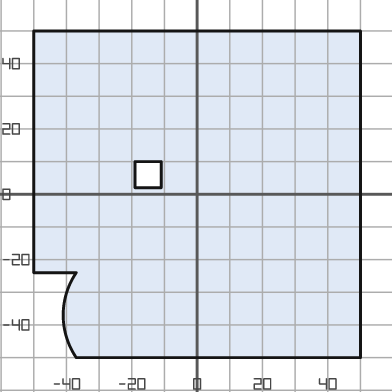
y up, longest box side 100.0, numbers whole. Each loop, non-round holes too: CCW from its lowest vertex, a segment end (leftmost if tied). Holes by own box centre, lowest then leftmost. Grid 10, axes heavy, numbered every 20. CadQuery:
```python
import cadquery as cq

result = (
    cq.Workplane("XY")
    .moveTo(-37.0, -50.0)
    .lineTo(50.0, -50.0)
    .lineTo(50.0, 50.0)
    .lineTo(-50.0, 50.0)
    .lineTo(-50.0, -24.0)
    .lineTo(-37.0, -24.0)
    .threePointArc((-41.0, -37.0), (-37.0, -50.0))
    .close()
    .moveTo(-19.0, 2.0)
    .lineTo(-11.0, 2.0)
    .lineTo(-11.0, 10.0)
    .lineTo(-19.0, 10.0)
    .close()
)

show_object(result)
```